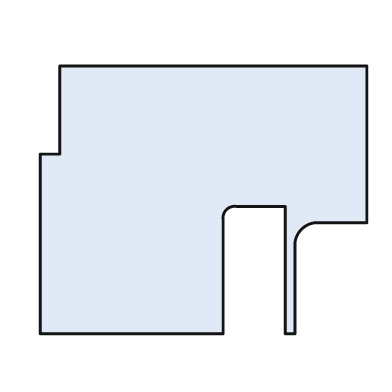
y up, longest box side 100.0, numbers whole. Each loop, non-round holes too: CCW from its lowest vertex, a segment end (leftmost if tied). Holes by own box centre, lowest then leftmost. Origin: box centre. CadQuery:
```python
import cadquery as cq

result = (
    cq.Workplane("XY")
    .moveTo(-50.0, -41.0)
    .lineTo(6.0, -41.0)
    .lineTo(6.0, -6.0)
    .threePointArc((7.0, -3.0), (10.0, -2.0))
    .lineTo(25.0, -2.0)
    .lineTo(25.0, -41.0)
    .lineTo(28.0, -41.0)
    .lineTo(28.0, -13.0)
    .threePointArc((30.0, -9.0), (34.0, -7.0))
    .lineTo(50.0, -7.0)
    .lineTo(50.0, 41.0)
    .lineTo(-44.0, 41.0)
    .lineTo(-44.0, 14.0)
    .lineTo(-50.0, 14.0)
    .close()
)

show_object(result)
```